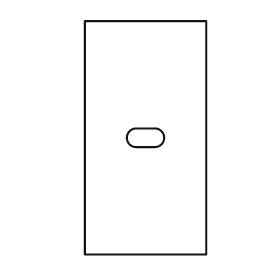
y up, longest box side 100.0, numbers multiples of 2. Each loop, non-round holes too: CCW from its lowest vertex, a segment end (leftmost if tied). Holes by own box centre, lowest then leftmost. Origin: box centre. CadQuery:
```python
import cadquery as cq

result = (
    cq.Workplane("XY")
    .moveTo(-26.0, -50.0)
    .lineTo(26.0, -50.0)
    .lineTo(26.0, 50.0)
    .lineTo(-26.0, 50.0)
    .close()
    .moveTo(-4.0, -4.0)
    .lineTo(4.0, -4.0)
    .threePointArc((8.0, 0.0), (4.0, 4.0))
    .lineTo(-4.0, 4.0)
    .threePointArc((-8.0, 0.0), (-4.0, -4.0))
    .close()
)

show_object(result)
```